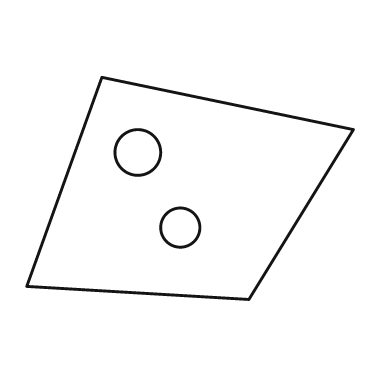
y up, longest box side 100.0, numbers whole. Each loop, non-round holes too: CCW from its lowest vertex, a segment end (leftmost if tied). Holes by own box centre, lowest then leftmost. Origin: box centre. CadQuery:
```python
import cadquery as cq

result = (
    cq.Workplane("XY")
    .moveTo(18.0, -34.0)
    .lineTo(50.0, 18.0)
    .lineTo(-27.0, 34.0)
    .lineTo(-50.0, -30.0)
    .close()
    .moveTo(-3.0, -12.0)
    .circle(6.0)
    .moveTo(-16.0, 11.0)
    .circle(7.0)
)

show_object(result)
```